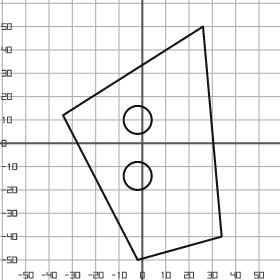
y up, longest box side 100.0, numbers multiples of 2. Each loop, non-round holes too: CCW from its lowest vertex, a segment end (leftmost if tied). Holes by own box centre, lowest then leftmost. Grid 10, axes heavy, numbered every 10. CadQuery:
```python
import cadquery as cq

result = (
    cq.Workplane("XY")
    .moveTo(-2.0, -50.0)
    .lineTo(34.0, -40.0)
    .lineTo(26.0, 50.0)
    .lineTo(-34.0, 12.0)
    .close()
    .moveTo(-2.0, -14.0)
    .circle(6.0)
    .moveTo(-2.0, 10.0)
    .circle(6.0)
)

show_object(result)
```